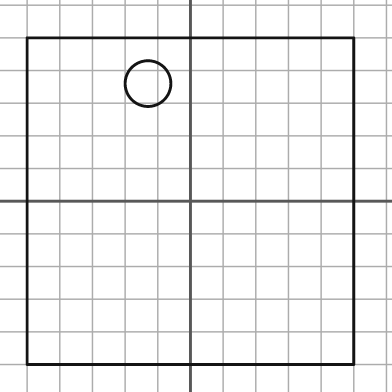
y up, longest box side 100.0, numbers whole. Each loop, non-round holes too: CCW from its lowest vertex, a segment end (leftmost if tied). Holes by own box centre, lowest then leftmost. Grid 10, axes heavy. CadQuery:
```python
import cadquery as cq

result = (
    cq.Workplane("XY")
    .moveTo(-50.0, -50.0)
    .lineTo(50.0, -50.0)
    .lineTo(50.0, 50.0)
    .lineTo(-50.0, 50.0)
    .close()
    .moveTo(-13.0, 36.0)
    .circle(7.0)
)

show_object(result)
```